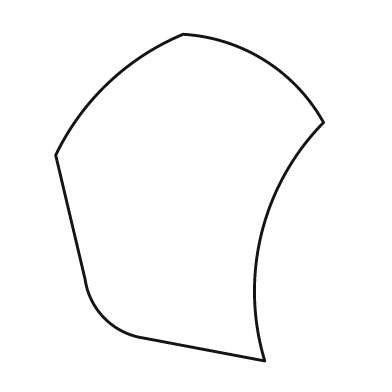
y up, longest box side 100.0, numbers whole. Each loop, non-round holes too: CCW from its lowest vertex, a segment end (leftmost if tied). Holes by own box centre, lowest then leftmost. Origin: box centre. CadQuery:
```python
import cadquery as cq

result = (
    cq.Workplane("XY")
    .moveTo(23.0, -50.0)
    .threePointArc((22.0, -11.0), (41.0, 23.0))
    .threePointArc((23.0, 42.0), (-2.0, 50.0))
    .threePointArc((-25.0, 35.0), (-41.0, 13.0))
    .lineTo(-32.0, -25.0)
    .threePointArc((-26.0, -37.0), (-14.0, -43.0))
    .close()
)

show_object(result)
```